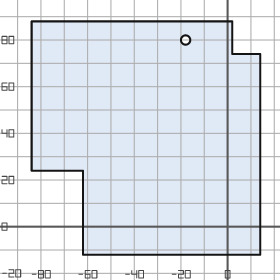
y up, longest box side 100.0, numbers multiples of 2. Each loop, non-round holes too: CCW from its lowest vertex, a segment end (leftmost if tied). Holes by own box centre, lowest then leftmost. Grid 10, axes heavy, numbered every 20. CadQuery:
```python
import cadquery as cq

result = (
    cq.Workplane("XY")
    .moveTo(-62.0, -12.0)
    .lineTo(14.0, -12.0)
    .lineTo(14.0, 74.0)
    .lineTo(2.0, 74.0)
    .lineTo(2.0, 88.0)
    .lineTo(-84.0, 88.0)
    .lineTo(-84.0, 24.0)
    .lineTo(-62.0, 24.0)
    .close()
    .moveTo(-18.0, 80.0)
    .circle(2.0)
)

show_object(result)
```